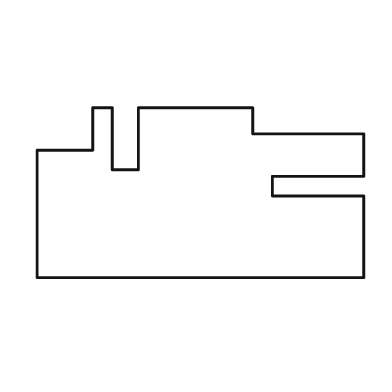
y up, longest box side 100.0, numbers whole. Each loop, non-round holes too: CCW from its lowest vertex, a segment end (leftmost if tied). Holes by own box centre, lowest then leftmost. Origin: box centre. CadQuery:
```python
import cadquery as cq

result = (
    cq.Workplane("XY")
    .moveTo(-50.0, -26.0)
    .lineTo(50.0, -26.0)
    .lineTo(50.0, -1.0)
    .lineTo(22.0, -1.0)
    .lineTo(22.0, 5.0)
    .lineTo(50.0, 5.0)
    .lineTo(50.0, 18.0)
    .lineTo(16.0, 18.0)
    .lineTo(16.0, 26.0)
    .lineTo(-19.0, 26.0)
    .lineTo(-19.0, 7.0)
    .lineTo(-27.0, 7.0)
    .lineTo(-27.0, 26.0)
    .lineTo(-33.0, 26.0)
    .lineTo(-33.0, 13.0)
    .lineTo(-50.0, 13.0)
    .close()
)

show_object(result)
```